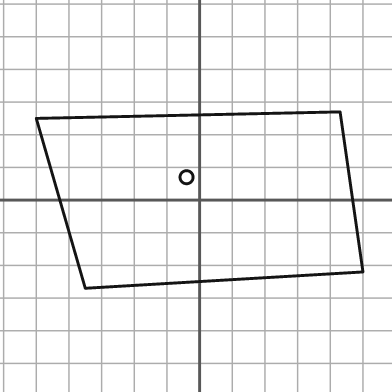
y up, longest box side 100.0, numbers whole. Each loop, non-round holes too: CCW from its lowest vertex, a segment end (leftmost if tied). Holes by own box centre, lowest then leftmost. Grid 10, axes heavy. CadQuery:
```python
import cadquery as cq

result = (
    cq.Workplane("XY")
    .moveTo(-35.0, -27.0)
    .lineTo(50.0, -22.0)
    .lineTo(43.0, 27.0)
    .lineTo(-50.0, 25.0)
    .close()
    .moveTo(-4.0, 7.0)
    .circle(2.0)
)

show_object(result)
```